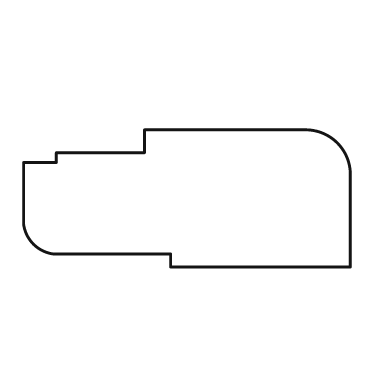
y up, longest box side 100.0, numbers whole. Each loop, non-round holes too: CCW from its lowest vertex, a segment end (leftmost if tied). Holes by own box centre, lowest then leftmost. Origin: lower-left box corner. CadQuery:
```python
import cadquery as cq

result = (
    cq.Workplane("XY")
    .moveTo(45.0, 0.0)
    .lineTo(100.0, 0.0)
    .lineTo(100.0, 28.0)
    .threePointArc((96.0, 38.0), (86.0, 42.0))
    .lineTo(37.0, 42.0)
    .lineTo(37.0, 35.0)
    .lineTo(10.0, 35.0)
    .lineTo(10.0, 32.0)
    .lineTo(0.0, 32.0)
    .lineTo(0.0, 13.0)
    .threePointArc((3.0, 7.0), (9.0, 4.0))
    .lineTo(45.0, 4.0)
    .close()
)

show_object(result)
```